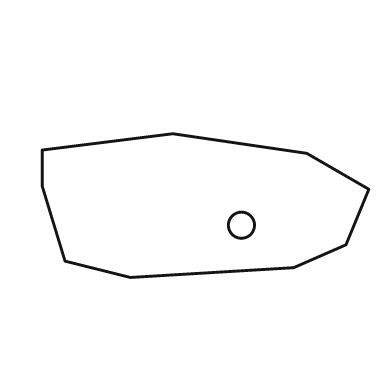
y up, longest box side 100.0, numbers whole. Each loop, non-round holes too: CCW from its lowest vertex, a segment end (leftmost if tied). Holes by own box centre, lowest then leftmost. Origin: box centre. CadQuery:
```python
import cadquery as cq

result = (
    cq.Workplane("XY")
    .moveTo(-23.0, -22.0)
    .lineTo(27.0, -19.0)
    .lineTo(43.0, -12.0)
    .lineTo(50.0, 5.0)
    .lineTo(31.0, 16.0)
    .lineTo(-10.0, 22.0)
    .lineTo(-50.0, 17.0)
    .lineTo(-50.0, 6.0)
    .lineTo(-43.0, -17.0)
    .close()
    .moveTo(11.0, -6.0)
    .circle(4.0)
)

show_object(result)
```